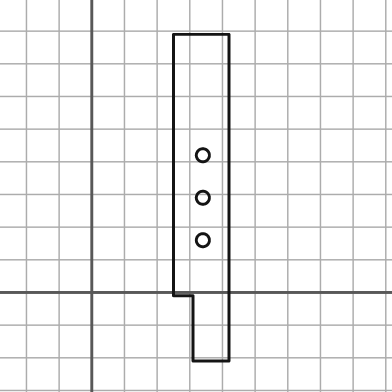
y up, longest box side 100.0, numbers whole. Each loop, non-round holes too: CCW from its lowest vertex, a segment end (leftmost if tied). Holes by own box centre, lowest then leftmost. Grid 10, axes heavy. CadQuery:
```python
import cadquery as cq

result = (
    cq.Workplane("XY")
    .moveTo(31.0, -21.0)
    .lineTo(42.0, -21.0)
    .lineTo(42.0, 79.0)
    .lineTo(25.0, 79.0)
    .lineTo(25.0, -1.0)
    .lineTo(31.0, -1.0)
    .close()
    .moveTo(34.0, 16.0)
    .circle(2.0)
    .moveTo(34.0, 29.0)
    .circle(2.0)
    .moveTo(34.0, 42.0)
    .circle(2.0)
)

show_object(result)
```